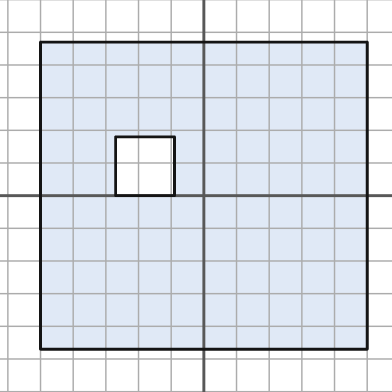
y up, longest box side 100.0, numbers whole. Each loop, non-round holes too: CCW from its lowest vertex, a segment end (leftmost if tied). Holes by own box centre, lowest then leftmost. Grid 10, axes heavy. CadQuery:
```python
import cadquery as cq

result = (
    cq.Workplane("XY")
    .moveTo(-50.0, -47.0)
    .lineTo(50.0, -47.0)
    .lineTo(50.0, 47.0)
    .lineTo(-50.0, 47.0)
    .close()
    .moveTo(-27.0, 0.0)
    .lineTo(-9.0, 0.0)
    .lineTo(-9.0, 18.0)
    .lineTo(-27.0, 18.0)
    .close()
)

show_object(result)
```